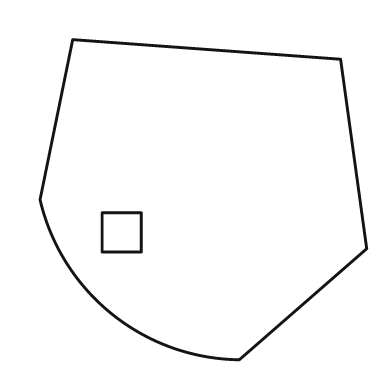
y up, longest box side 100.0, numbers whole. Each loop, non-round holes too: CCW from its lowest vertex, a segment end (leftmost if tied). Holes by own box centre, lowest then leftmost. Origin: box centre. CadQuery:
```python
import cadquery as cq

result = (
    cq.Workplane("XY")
    .moveTo(11.0, -49.0)
    .lineTo(50.0, -15.0)
    .lineTo(42.0, 43.0)
    .lineTo(-40.0, 49.0)
    .lineTo(-50.0, 0.0)
    .threePointArc((-28.0, -35.0), (11.0, -49.0))
    .close()
    .moveTo(-31.0, -16.0)
    .lineTo(-19.0, -16.0)
    .lineTo(-19.0, -4.0)
    .lineTo(-31.0, -4.0)
    .close()
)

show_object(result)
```